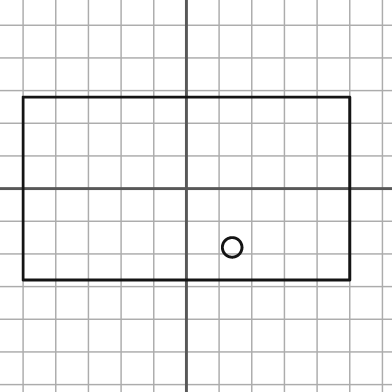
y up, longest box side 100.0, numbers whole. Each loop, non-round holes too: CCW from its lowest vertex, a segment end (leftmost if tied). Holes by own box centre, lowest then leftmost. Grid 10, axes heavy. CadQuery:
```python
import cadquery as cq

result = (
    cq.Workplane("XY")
    .moveTo(-50.0, -28.0)
    .lineTo(50.0, -28.0)
    .lineTo(50.0, 28.0)
    .lineTo(-50.0, 28.0)
    .close()
    .moveTo(14.0, -18.0)
    .circle(3.0)
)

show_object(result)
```